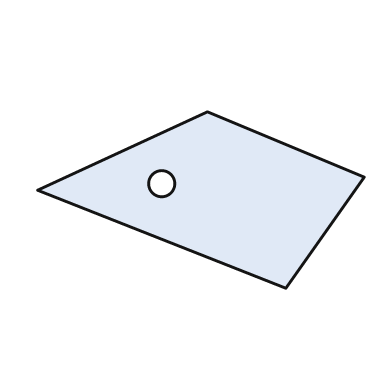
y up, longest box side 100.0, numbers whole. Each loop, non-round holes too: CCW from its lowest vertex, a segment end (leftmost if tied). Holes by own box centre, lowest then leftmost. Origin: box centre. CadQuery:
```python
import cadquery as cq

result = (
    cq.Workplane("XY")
    .moveTo(26.0, -27.0)
    .lineTo(50.0, 7.0)
    .lineTo(2.0, 27.0)
    .lineTo(-50.0, 3.0)
    .close()
    .moveTo(-12.0, 5.0)
    .circle(4.0)
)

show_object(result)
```